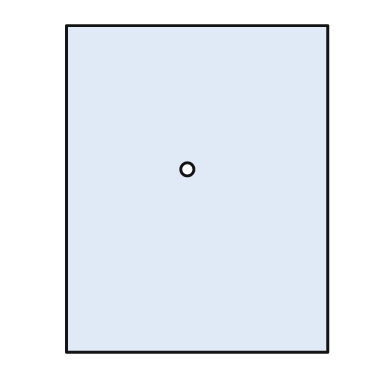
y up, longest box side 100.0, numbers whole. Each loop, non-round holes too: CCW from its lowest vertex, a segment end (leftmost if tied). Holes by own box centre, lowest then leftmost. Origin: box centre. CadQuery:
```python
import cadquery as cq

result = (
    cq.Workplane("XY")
    .moveTo(-40.0, -50.0)
    .lineTo(40.0, -50.0)
    .lineTo(40.0, 50.0)
    .lineTo(-40.0, 50.0)
    .close()
    .moveTo(-3.0, 6.0)
    .circle(2.0)
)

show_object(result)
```